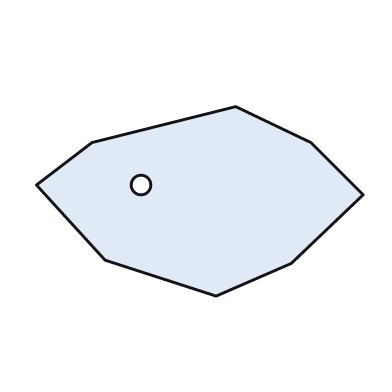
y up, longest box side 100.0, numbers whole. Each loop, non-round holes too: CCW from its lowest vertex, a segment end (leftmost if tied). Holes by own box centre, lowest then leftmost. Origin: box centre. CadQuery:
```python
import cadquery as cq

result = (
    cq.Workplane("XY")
    .moveTo(5.0, -29.0)
    .lineTo(28.0, -19.0)
    .lineTo(50.0, 2.0)
    .lineTo(34.0, 18.0)
    .lineTo(11.0, 29.0)
    .lineTo(-33.0, 18.0)
    .lineTo(-50.0, 5.0)
    .lineTo(-29.0, -18.0)
    .close()
    .moveTo(-18.0, 5.0)
    .circle(3.0)
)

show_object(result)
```